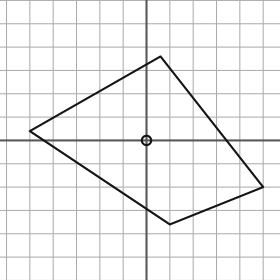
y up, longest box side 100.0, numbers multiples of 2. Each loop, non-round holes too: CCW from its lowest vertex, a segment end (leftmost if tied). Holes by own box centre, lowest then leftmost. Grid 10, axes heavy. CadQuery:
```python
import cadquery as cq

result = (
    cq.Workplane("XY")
    .moveTo(10.0, -36.0)
    .lineTo(50.0, -20.0)
    .lineTo(6.0, 36.0)
    .lineTo(-50.0, 4.0)
    .close()
    .moveTo(0.0, 0.0)
    .circle(2.0)
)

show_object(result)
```